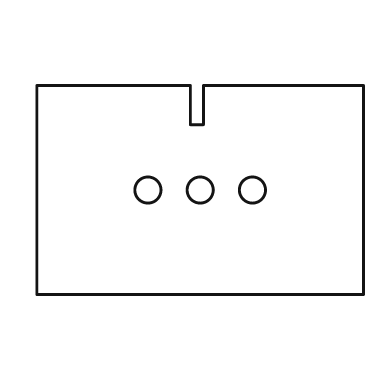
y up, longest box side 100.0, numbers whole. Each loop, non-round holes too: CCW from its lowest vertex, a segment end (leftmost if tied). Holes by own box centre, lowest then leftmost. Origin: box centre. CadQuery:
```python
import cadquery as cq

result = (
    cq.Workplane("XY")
    .moveTo(-50.0, -32.0)
    .lineTo(50.0, -32.0)
    .lineTo(50.0, 32.0)
    .lineTo(1.0, 32.0)
    .lineTo(1.0, 20.0)
    .lineTo(-3.0, 20.0)
    .lineTo(-3.0, 32.0)
    .lineTo(-50.0, 32.0)
    .close()
    .moveTo(-16.0, 0.0)
    .circle(4.0)
    .moveTo(0.0, 0.0)
    .circle(4.0)
    .moveTo(16.0, 0.0)
    .circle(4.0)
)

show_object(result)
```